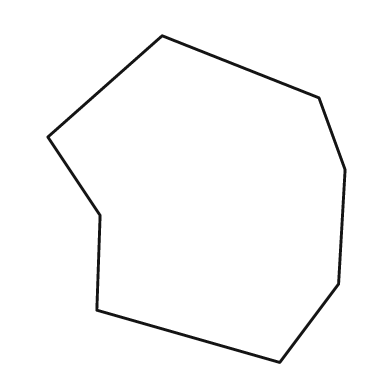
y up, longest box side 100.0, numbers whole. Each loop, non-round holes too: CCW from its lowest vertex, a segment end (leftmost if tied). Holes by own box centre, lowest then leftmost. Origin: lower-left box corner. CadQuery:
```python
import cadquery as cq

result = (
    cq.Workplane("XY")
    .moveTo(71.0, 0.0)
    .lineTo(89.0, 24.0)
    .lineTo(91.0, 59.0)
    .lineTo(83.0, 81.0)
    .lineTo(35.0, 100.0)
    .lineTo(0.0, 69.0)
    .lineTo(16.0, 45.0)
    .lineTo(15.0, 16.0)
    .close()
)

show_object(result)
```